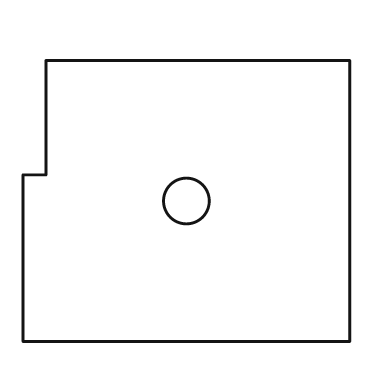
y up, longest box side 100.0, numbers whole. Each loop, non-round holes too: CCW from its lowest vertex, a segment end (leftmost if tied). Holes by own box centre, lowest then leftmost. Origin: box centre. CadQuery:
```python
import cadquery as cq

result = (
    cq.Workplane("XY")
    .moveTo(-50.0, -43.0)
    .lineTo(50.0, -43.0)
    .lineTo(50.0, 43.0)
    .lineTo(-43.0, 43.0)
    .lineTo(-43.0, 8.0)
    .lineTo(-50.0, 8.0)
    .close()
    .moveTo(0.0, 0.0)
    .circle(7.0)
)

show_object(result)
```